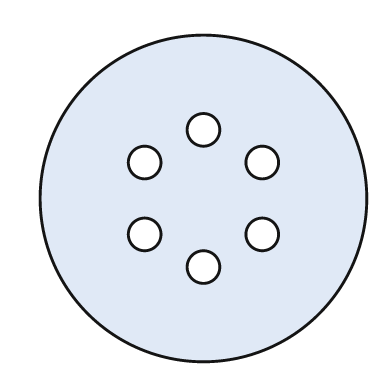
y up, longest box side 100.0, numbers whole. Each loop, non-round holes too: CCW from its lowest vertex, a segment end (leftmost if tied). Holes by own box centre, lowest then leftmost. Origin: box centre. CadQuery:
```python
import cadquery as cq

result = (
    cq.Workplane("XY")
    .moveTo(0.0, 0.0)
    .circle(50.0)
    .moveTo(0.0, -21.0)
    .circle(5.0)
    .moveTo(-18.0, -11.0)
    .circle(5.0)
    .moveTo(18.0, -11.0)
    .circle(5.0)
    .moveTo(-18.0, 11.0)
    .circle(5.0)
    .moveTo(18.0, 11.0)
    .circle(5.0)
    .moveTo(0.0, 21.0)
    .circle(5.0)
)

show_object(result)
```